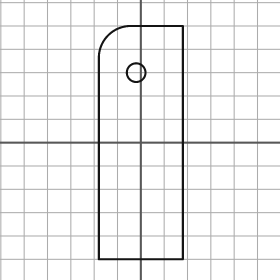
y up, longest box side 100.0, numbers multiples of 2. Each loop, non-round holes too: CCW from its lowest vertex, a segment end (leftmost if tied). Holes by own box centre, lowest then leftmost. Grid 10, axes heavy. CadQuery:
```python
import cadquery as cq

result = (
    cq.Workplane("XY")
    .moveTo(-18.0, -50.0)
    .lineTo(18.0, -50.0)
    .lineTo(18.0, 50.0)
    .lineTo(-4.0, 50.0)
    .threePointArc((-14.0, 46.0), (-18.0, 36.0))
    .close()
    .moveTo(-2.0, 30.0)
    .circle(4.0)
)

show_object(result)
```